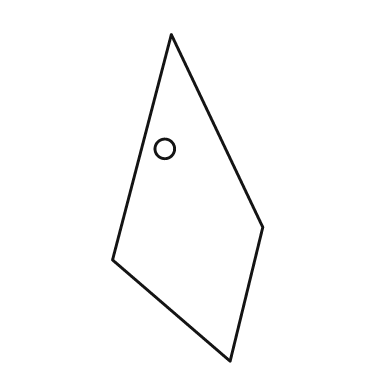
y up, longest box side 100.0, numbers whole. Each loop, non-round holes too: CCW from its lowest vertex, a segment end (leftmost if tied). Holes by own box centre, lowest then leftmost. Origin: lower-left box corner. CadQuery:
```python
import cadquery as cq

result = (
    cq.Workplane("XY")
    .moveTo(36.0, 0.0)
    .lineTo(46.0, 41.0)
    .lineTo(18.0, 100.0)
    .lineTo(0.0, 31.0)
    .close()
    .moveTo(16.0, 65.0)
    .circle(3.0)
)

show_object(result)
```